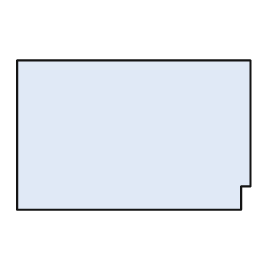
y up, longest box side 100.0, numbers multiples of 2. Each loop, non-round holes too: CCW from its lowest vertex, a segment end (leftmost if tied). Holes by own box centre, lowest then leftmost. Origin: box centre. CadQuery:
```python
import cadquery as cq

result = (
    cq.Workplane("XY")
    .moveTo(-50.0, -32.0)
    .lineTo(46.0, -32.0)
    .lineTo(46.0, -22.0)
    .lineTo(50.0, -22.0)
    .lineTo(50.0, 32.0)
    .lineTo(-50.0, 32.0)
    .close()
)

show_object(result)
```